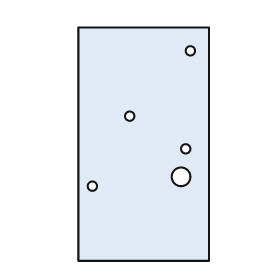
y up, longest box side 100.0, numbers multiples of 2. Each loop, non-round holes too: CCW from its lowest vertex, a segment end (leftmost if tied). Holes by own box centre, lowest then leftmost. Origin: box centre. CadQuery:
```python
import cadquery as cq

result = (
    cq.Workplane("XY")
    .moveTo(-28.0, -50.0)
    .lineTo(28.0, -50.0)
    .lineTo(28.0, 50.0)
    .lineTo(-28.0, 50.0)
    .close()
    .moveTo(-22.0, -18.0)
    .circle(2.0)
    .moveTo(16.0, -14.0)
    .circle(4.0)
    .moveTo(18.0, -2.0)
    .circle(2.0)
    .moveTo(-6.0, 12.0)
    .circle(2.0)
    .moveTo(20.0, 40.0)
    .circle(2.0)
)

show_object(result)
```